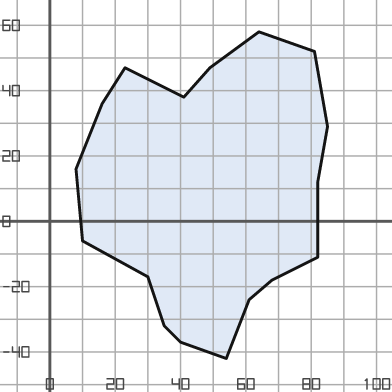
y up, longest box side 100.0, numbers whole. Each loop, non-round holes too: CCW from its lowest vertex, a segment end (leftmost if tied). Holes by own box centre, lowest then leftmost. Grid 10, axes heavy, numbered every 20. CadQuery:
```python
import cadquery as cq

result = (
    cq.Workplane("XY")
    .moveTo(54.0, -42.0)
    .lineTo(61.0, -24.0)
    .lineTo(68.0, -18.0)
    .lineTo(82.0, -11.0)
    .lineTo(82.0, 12.0)
    .lineTo(85.0, 29.0)
    .lineTo(81.0, 52.0)
    .lineTo(64.0, 58.0)
    .lineTo(49.0, 47.0)
    .lineTo(41.0, 38.0)
    .lineTo(23.0, 47.0)
    .lineTo(16.0, 36.0)
    .lineTo(8.0, 16.0)
    .lineTo(10.0, -6.0)
    .lineTo(30.0, -17.0)
    .lineTo(35.0, -32.0)
    .lineTo(40.0, -37.0)
    .close()
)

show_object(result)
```